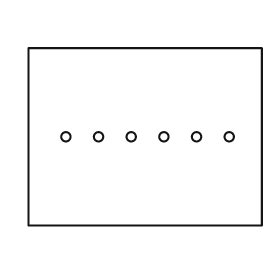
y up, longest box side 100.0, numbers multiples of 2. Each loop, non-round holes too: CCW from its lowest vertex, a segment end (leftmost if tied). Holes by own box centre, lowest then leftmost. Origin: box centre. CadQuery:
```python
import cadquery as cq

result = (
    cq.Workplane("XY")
    .moveTo(-50.0, -38.0)
    .lineTo(50.0, -38.0)
    .lineTo(50.0, 38.0)
    .lineTo(-50.0, 38.0)
    .close()
    .moveTo(-34.0, 0.0)
    .circle(2.0)
    .moveTo(-20.0, 0.0)
    .circle(2.0)
    .moveTo(-6.0, 0.0)
    .circle(2.0)
    .moveTo(8.0, 0.0)
    .circle(2.0)
    .moveTo(22.0, 0.0)
    .circle(2.0)
    .moveTo(36.0, 0.0)
    .circle(2.0)
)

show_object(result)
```